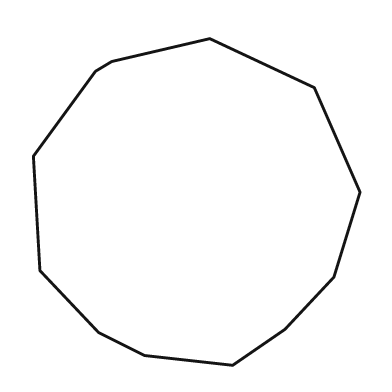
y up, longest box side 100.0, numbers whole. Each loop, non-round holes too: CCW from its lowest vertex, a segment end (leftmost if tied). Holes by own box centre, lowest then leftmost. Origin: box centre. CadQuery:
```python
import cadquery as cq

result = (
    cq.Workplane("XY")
    .moveTo(11.0, -50.0)
    .lineTo(27.0, -39.0)
    .lineTo(42.0, -23.0)
    .lineTo(50.0, 3.0)
    .lineTo(36.0, 35.0)
    .lineTo(4.0, 50.0)
    .lineTo(-26.0, 43.0)
    .lineTo(-31.0, 40.0)
    .lineTo(-50.0, 14.0)
    .lineTo(-48.0, -21.0)
    .lineTo(-30.0, -40.0)
    .lineTo(-16.0, -47.0)
    .close()
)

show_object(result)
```